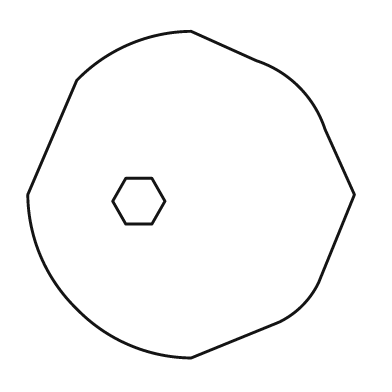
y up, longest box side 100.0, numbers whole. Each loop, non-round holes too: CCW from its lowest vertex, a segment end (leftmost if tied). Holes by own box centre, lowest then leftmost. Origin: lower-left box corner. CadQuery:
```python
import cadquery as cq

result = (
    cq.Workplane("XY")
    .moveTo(50.0, 0.0)
    .lineTo(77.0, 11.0)
    .threePointArc((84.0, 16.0), (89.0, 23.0))
    .lineTo(100.0, 50.0)
    .lineTo(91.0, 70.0)
    .threePointArc((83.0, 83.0), (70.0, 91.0))
    .lineTo(50.0, 100.0)
    .threePointArc((31.0, 96.0), (15.0, 85.0))
    .lineTo(0.0, 50.0)
    .threePointArc((4.0, 31.0), (15.0, 15.0))
    .threePointArc((31.0, 4.0), (50.0, 0.0))
    .close()
    .moveTo(30.0, 41.0)
    .lineTo(38.0, 41.0)
    .lineTo(42.0, 48.0)
    .lineTo(38.0, 55.0)
    .lineTo(30.0, 55.0)
    .lineTo(26.0, 48.0)
    .close()
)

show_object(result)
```